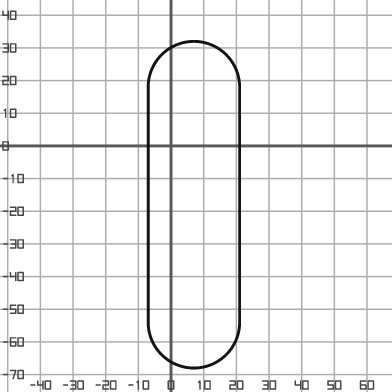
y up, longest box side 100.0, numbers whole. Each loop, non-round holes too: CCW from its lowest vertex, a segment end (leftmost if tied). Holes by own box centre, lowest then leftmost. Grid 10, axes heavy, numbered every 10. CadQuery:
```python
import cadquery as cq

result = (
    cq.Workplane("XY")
    .moveTo(-7.0, -54.0)
    .threePointArc((7.0, -68.0), (21.0, -54.0))
    .lineTo(21.0, 18.0)
    .threePointArc((7.0, 32.0), (-7.0, 18.0))
    .close()
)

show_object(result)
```